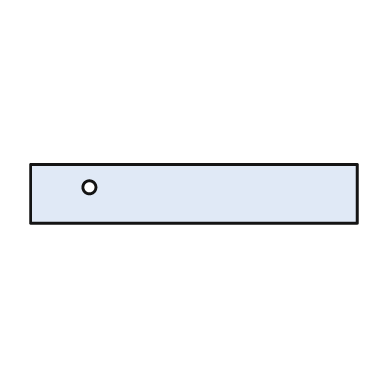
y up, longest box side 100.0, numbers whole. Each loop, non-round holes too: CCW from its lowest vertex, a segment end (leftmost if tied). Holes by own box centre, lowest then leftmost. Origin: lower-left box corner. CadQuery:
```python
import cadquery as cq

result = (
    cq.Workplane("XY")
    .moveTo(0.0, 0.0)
    .lineTo(100.0, 0.0)
    .lineTo(100.0, 18.0)
    .lineTo(0.0, 18.0)
    .close()
    .moveTo(18.0, 11.0)
    .circle(2.0)
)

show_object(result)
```